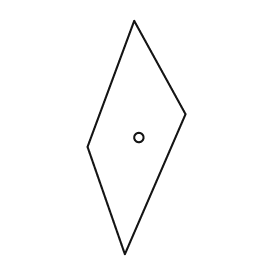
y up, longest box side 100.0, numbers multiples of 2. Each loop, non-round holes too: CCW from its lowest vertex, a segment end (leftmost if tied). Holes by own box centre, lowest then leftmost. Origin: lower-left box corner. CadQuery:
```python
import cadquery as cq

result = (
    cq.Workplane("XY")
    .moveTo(16.0, 0.0)
    .lineTo(42.0, 60.0)
    .lineTo(20.0, 100.0)
    .lineTo(0.0, 46.0)
    .close()
    .moveTo(22.0, 50.0)
    .circle(2.0)
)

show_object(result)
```